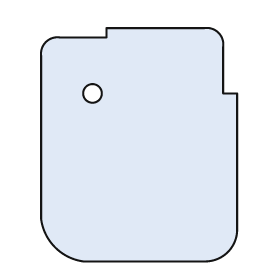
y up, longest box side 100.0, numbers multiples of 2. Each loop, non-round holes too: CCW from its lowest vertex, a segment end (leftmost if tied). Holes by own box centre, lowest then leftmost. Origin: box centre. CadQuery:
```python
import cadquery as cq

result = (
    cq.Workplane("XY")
    .moveTo(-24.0, -50.0)
    .lineTo(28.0, -50.0)
    .threePointArc((38.0, -46.0), (42.0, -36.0))
    .lineTo(42.0, 22.0)
    .lineTo(36.0, 22.0)
    .lineTo(36.0, 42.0)
    .threePointArc((34.0, 48.0), (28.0, 50.0))
    .lineTo(-14.0, 50.0)
    .lineTo(-14.0, 46.0)
    .lineTo(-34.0, 46.0)
    .threePointArc((-40.0, 44.0), (-42.0, 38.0))
    .lineTo(-42.0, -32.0)
    .threePointArc((-36.0, -44.0), (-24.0, -50.0))
    .close()
    .moveTo(-20.0, 22.0)
    .circle(4.0)
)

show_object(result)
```